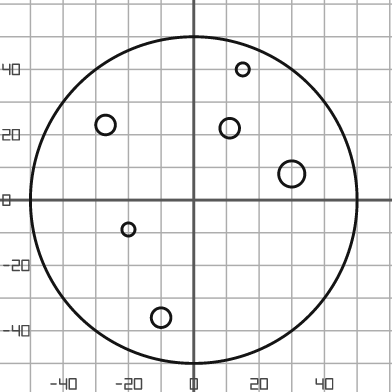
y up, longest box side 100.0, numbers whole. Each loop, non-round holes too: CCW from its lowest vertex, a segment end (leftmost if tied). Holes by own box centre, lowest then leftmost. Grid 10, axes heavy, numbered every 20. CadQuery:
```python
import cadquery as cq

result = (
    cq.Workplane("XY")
    .moveTo(0.0, 0.0)
    .circle(50.0)
    .moveTo(-10.0, -36.0)
    .circle(3.0)
    .moveTo(-20.0, -9.0)
    .circle(2.0)
    .moveTo(30.0, 8.0)
    .circle(4.0)
    .moveTo(11.0, 22.0)
    .circle(3.0)
    .moveTo(-27.0, 23.0)
    .circle(3.0)
    .moveTo(15.0, 40.0)
    .circle(2.0)
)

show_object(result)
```